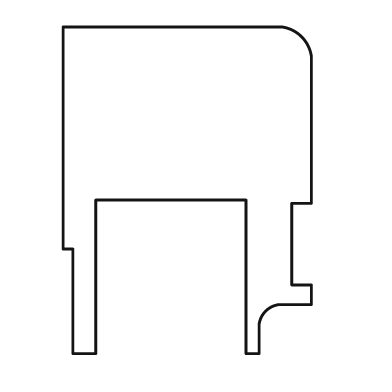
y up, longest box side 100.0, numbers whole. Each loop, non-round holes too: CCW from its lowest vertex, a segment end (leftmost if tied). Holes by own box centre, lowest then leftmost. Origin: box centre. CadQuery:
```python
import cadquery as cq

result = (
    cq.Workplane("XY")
    .moveTo(-35.0, -50.0)
    .lineTo(-28.0, -50.0)
    .lineTo(-28.0, -3.0)
    .lineTo(18.0, -3.0)
    .lineTo(18.0, -50.0)
    .lineTo(22.0, -50.0)
    .lineTo(22.0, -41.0)
    .threePointArc((24.0, -37.0), (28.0, -35.0))
    .lineTo(38.0, -35.0)
    .lineTo(38.0, -29.0)
    .lineTo(32.0, -29.0)
    .lineTo(32.0, -4.0)
    .lineTo(38.0, -4.0)
    .lineTo(38.0, 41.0)
    .threePointArc((35.0, 47.0), (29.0, 50.0))
    .lineTo(-38.0, 50.0)
    .lineTo(-38.0, -18.0)
    .lineTo(-35.0, -18.0)
    .close()
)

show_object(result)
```